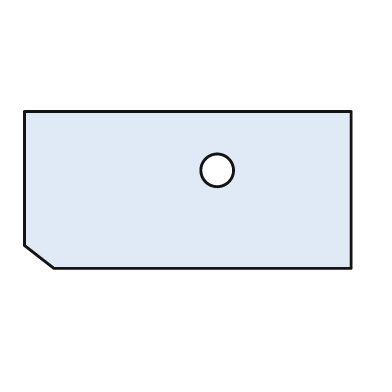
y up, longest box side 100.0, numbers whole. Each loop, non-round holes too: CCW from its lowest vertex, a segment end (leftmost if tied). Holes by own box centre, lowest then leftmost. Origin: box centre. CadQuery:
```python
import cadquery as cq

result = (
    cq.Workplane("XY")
    .moveTo(-41.0, -24.0)
    .lineTo(50.0, -24.0)
    .lineTo(50.0, 24.0)
    .lineTo(-50.0, 24.0)
    .lineTo(-50.0, -17.0)
    .close()
    .moveTo(9.0, 6.0)
    .circle(5.0)
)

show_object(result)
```